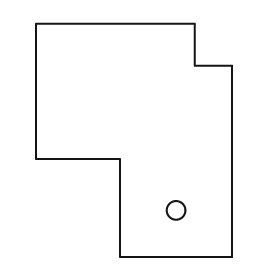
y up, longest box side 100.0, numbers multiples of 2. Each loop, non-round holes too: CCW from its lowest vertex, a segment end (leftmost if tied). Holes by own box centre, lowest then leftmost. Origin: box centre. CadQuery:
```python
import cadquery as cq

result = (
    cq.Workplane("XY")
    .moveTo(-6.0, -50.0)
    .lineTo(42.0, -50.0)
    .lineTo(42.0, 32.0)
    .lineTo(26.0, 32.0)
    .lineTo(26.0, 50.0)
    .lineTo(-42.0, 50.0)
    .lineTo(-42.0, -8.0)
    .lineTo(-6.0, -8.0)
    .close()
    .moveTo(18.0, -30.0)
    .circle(4.0)
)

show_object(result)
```